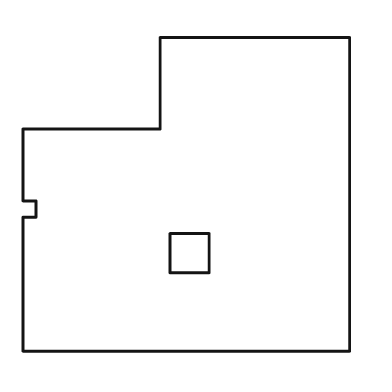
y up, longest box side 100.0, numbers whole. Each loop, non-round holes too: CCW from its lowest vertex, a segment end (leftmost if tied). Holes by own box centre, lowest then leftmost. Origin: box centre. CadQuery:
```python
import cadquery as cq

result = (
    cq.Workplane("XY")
    .moveTo(-50.0, -48.0)
    .lineTo(50.0, -48.0)
    .lineTo(50.0, 48.0)
    .lineTo(-8.0, 48.0)
    .lineTo(-8.0, 20.0)
    .lineTo(-50.0, 20.0)
    .lineTo(-50.0, -2.0)
    .lineTo(-46.0, -2.0)
    .lineTo(-46.0, -7.0)
    .lineTo(-50.0, -7.0)
    .close()
    .moveTo(-5.0, -24.0)
    .lineTo(7.0, -24.0)
    .lineTo(7.0, -12.0)
    .lineTo(-5.0, -12.0)
    .close()
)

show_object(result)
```